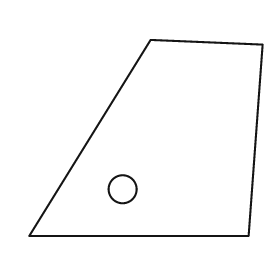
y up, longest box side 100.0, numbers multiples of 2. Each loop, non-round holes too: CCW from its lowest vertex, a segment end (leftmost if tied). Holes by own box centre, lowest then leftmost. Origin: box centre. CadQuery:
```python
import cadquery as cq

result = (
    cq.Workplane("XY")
    .moveTo(-50.0, -42.0)
    .lineTo(44.0, -42.0)
    .lineTo(50.0, 40.0)
    .lineTo(2.0, 42.0)
    .close()
    .moveTo(-10.0, -22.0)
    .circle(6.0)
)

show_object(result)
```